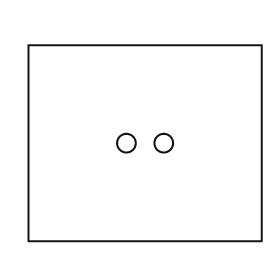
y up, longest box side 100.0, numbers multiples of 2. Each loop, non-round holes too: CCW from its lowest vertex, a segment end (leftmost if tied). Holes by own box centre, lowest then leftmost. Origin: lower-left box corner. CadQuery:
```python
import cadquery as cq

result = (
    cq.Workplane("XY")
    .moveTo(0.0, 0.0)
    .lineTo(100.0, 0.0)
    .lineTo(100.0, 84.0)
    .lineTo(0.0, 84.0)
    .close()
    .moveTo(42.0, 42.0)
    .circle(4.0)
    .moveTo(58.0, 42.0)
    .circle(4.0)
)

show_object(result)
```